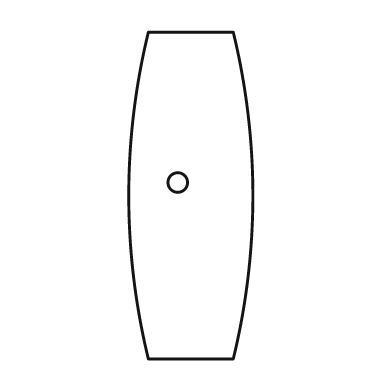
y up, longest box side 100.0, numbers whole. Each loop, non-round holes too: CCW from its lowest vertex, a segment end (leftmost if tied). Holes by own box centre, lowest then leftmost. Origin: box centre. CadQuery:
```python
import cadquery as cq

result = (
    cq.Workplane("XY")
    .moveTo(-13.0, -50.0)
    .lineTo(13.0, -50.0)
    .threePointArc((19.0, 0.0), (13.0, 50.0))
    .lineTo(-13.0, 50.0)
    .threePointArc((-19.0, 0.0), (-13.0, -50.0))
    .close()
    .moveTo(-4.0, 4.0)
    .circle(3.0)
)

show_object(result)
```